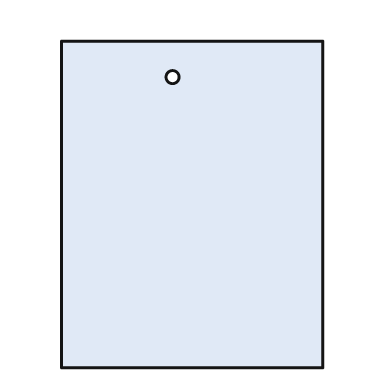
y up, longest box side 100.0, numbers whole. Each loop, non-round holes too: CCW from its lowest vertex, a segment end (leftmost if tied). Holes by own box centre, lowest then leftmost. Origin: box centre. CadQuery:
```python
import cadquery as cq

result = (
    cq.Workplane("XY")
    .moveTo(-40.0, -50.0)
    .lineTo(40.0, -50.0)
    .lineTo(40.0, 50.0)
    .lineTo(-40.0, 50.0)
    .close()
    .moveTo(-6.0, 39.0)
    .circle(2.0)
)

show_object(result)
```